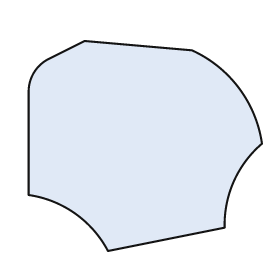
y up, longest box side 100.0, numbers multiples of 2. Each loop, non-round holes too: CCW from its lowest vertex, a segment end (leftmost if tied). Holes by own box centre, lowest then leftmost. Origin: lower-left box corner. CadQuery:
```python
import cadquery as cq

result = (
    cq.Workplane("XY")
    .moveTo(34.0, 0.0)
    .lineTo(84.0, 10.0)
    .threePointArc((88.0, 30.0), (100.0, 46.0))
    .threePointArc((90.0, 70.0), (70.0, 86.0))
    .lineTo(24.0, 90.0)
    .lineTo(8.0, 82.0)
    .threePointArc((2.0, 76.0), (0.0, 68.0))
    .lineTo(0.0, 24.0)
    .threePointArc((20.0, 16.0), (34.0, 0.0))
    .close()
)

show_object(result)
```